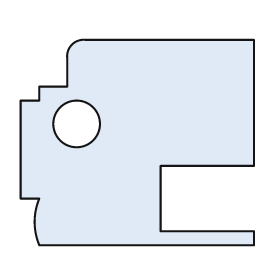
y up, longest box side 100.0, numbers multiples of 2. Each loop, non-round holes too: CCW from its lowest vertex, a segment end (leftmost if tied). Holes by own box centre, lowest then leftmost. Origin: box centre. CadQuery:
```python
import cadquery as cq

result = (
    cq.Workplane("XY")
    .moveTo(-42.0, -44.0)
    .lineTo(50.0, -44.0)
    .lineTo(50.0, -38.0)
    .lineTo(10.0, -38.0)
    .lineTo(10.0, -10.0)
    .lineTo(50.0, -10.0)
    .lineTo(50.0, 44.0)
    .lineTo(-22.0, 44.0)
    .threePointArc((-28.0, 42.0), (-30.0, 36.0))
    .lineTo(-30.0, 24.0)
    .lineTo(-42.0, 24.0)
    .lineTo(-42.0, 18.0)
    .lineTo(-50.0, 18.0)
    .lineTo(-50.0, -24.0)
    .lineTo(-42.0, -24.0)
    .threePointArc((-44.0, -34.0), (-42.0, -44.0))
    .close()
    .moveTo(-26.0, 8.0)
    .circle(10.0)
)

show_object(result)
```